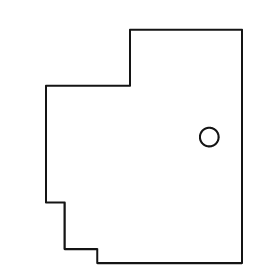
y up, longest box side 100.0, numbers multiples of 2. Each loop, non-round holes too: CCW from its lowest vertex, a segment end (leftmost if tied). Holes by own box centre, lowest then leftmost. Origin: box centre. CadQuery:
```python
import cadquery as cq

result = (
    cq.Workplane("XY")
    .moveTo(-20.0, -50.0)
    .lineTo(42.0, -50.0)
    .lineTo(42.0, 50.0)
    .lineTo(-6.0, 50.0)
    .lineTo(-6.0, 26.0)
    .lineTo(-42.0, 26.0)
    .lineTo(-42.0, -24.0)
    .lineTo(-34.0, -24.0)
    .lineTo(-34.0, -44.0)
    .lineTo(-20.0, -44.0)
    .close()
    .moveTo(28.0, 4.0)
    .circle(4.0)
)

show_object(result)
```